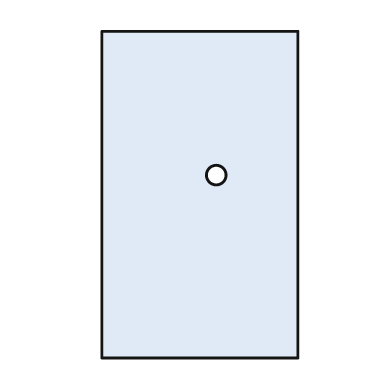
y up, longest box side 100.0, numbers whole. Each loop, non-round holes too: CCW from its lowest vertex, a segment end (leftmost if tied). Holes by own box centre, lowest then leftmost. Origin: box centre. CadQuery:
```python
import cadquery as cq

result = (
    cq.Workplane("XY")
    .moveTo(-30.0, -50.0)
    .lineTo(30.0, -50.0)
    .lineTo(30.0, 50.0)
    .lineTo(-30.0, 50.0)
    .close()
    .moveTo(5.0, 6.0)
    .circle(3.0)
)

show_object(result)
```